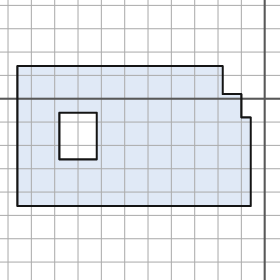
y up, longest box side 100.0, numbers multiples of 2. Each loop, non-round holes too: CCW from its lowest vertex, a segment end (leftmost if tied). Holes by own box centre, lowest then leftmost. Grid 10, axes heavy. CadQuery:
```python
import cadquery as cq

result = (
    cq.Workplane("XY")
    .moveTo(-106.0, -46.0)
    .lineTo(-6.0, -46.0)
    .lineTo(-6.0, -8.0)
    .lineTo(-10.0, -8.0)
    .lineTo(-10.0, 2.0)
    .lineTo(-18.0, 2.0)
    .lineTo(-18.0, 14.0)
    .lineTo(-106.0, 14.0)
    .close()
    .moveTo(-88.0, -26.0)
    .lineTo(-72.0, -26.0)
    .lineTo(-72.0, -6.0)
    .lineTo(-88.0, -6.0)
    .close()
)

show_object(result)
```